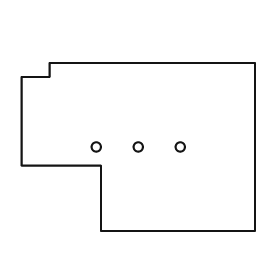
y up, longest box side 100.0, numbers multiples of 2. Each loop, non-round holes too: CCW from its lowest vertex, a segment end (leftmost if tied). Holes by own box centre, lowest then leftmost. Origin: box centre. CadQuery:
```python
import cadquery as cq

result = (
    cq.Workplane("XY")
    .moveTo(-16.0, -36.0)
    .lineTo(50.0, -36.0)
    .lineTo(50.0, 36.0)
    .lineTo(-38.0, 36.0)
    .lineTo(-38.0, 30.0)
    .lineTo(-50.0, 30.0)
    .lineTo(-50.0, -8.0)
    .lineTo(-16.0, -8.0)
    .close()
    .moveTo(-18.0, 0.0)
    .circle(2.0)
    .moveTo(0.0, 0.0)
    .circle(2.0)
    .moveTo(18.0, 0.0)
    .circle(2.0)
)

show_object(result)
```